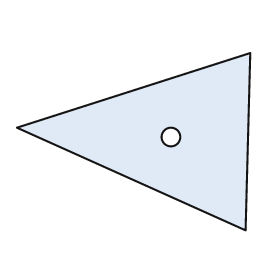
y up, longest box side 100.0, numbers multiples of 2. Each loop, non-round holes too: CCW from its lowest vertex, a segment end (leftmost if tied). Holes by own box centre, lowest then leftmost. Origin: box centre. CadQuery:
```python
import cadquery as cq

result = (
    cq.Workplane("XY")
    .moveTo(48.0, -38.0)
    .lineTo(50.0, 38.0)
    .lineTo(-50.0, 6.0)
    .close()
    .moveTo(16.0, 2.0)
    .circle(4.0)
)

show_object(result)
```